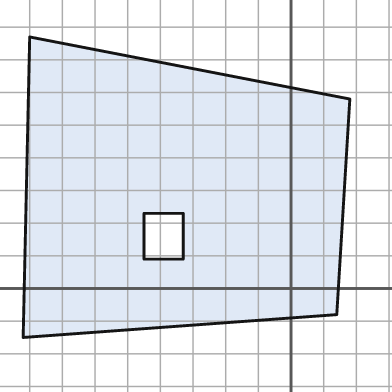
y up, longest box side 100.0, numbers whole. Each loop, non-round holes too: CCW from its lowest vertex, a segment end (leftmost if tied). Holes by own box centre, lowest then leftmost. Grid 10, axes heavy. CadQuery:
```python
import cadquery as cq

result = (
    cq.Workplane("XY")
    .moveTo(-82.0, -15.0)
    .lineTo(14.0, -8.0)
    .lineTo(18.0, 58.0)
    .lineTo(-80.0, 77.0)
    .close()
    .moveTo(-45.0, 9.0)
    .lineTo(-33.0, 9.0)
    .lineTo(-33.0, 23.0)
    .lineTo(-45.0, 23.0)
    .close()
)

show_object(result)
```